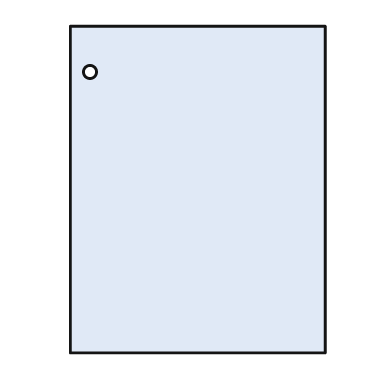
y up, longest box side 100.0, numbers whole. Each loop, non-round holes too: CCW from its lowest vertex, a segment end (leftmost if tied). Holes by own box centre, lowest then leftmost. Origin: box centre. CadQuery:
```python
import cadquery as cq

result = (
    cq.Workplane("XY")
    .moveTo(-39.0, -50.0)
    .lineTo(39.0, -50.0)
    .lineTo(39.0, 50.0)
    .lineTo(-39.0, 50.0)
    .close()
    .moveTo(-33.0, 36.0)
    .circle(2.0)
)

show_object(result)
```